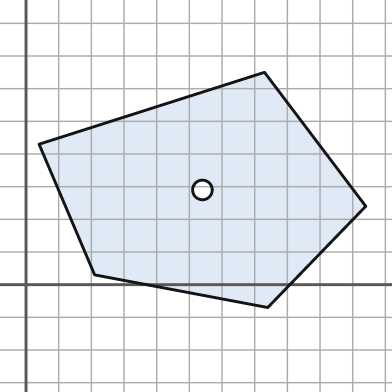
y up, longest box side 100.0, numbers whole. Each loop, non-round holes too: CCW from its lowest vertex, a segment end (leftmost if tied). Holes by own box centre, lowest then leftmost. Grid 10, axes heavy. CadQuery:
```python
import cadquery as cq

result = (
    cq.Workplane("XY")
    .moveTo(74.0, -7.0)
    .lineTo(104.0, 24.0)
    .lineTo(73.0, 65.0)
    .lineTo(4.0, 43.0)
    .lineTo(21.0, 3.0)
    .close()
    .moveTo(54.0, 29.0)
    .circle(3.0)
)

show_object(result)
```